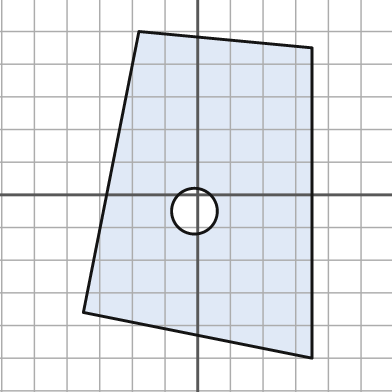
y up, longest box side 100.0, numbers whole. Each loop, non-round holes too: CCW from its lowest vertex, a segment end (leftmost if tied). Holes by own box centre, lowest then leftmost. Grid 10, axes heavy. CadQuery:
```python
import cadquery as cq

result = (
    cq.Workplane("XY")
    .moveTo(35.0, -50.0)
    .lineTo(35.0, 45.0)
    .lineTo(-18.0, 50.0)
    .lineTo(-35.0, -36.0)
    .close()
    .moveTo(-1.0, -5.0)
    .circle(7.0)
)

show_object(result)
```